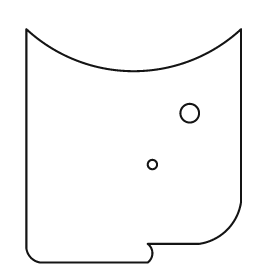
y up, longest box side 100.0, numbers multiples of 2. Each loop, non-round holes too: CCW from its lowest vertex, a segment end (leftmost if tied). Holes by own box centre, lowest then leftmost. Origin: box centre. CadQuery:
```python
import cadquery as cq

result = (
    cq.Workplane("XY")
    .moveTo(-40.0, -50.0)
    .lineTo(6.0, -50.0)
    .threePointArc((8.0, -46.0), (6.0, -42.0))
    .lineTo(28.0, -42.0)
    .threePointArc((40.0, -36.0), (46.0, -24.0))
    .lineTo(46.0, 50.0)
    .threePointArc((0.0, 32.0), (-46.0, 50.0))
    .lineTo(-46.0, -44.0)
    .threePointArc((-44.0, -48.0), (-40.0, -50.0))
    .close()
    .moveTo(8.0, -8.0)
    .circle(2.0)
    .moveTo(24.0, 14.0)
    .circle(4.0)
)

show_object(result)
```